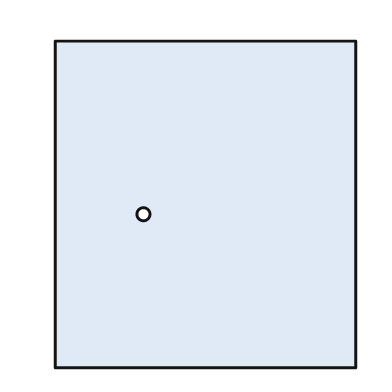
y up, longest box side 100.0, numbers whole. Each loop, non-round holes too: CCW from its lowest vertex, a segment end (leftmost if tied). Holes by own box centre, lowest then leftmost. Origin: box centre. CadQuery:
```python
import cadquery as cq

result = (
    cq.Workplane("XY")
    .moveTo(-46.0, -50.0)
    .lineTo(46.0, -50.0)
    .lineTo(46.0, 50.0)
    .lineTo(-46.0, 50.0)
    .close()
    .moveTo(-19.0, -3.0)
    .circle(2.0)
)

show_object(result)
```